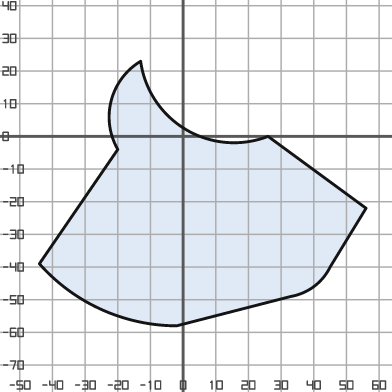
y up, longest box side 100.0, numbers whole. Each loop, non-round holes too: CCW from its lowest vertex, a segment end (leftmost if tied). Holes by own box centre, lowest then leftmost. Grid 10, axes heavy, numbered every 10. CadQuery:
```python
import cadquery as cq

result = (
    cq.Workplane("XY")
    .moveTo(-2.0, -58.0)
    .lineTo(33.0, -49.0)
    .threePointArc((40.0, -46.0), (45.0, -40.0))
    .lineTo(56.0, -22.0)
    .lineTo(26.0, 0.0)
    .threePointArc((1.0, 2.0), (-13.0, 23.0))
    .threePointArc((-22.0, 11.0), (-20.0, -4.0))
    .lineTo(-44.0, -39.0)
    .threePointArc((-25.0, -53.0), (-2.0, -58.0))
    .close()
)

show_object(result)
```